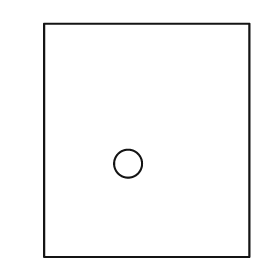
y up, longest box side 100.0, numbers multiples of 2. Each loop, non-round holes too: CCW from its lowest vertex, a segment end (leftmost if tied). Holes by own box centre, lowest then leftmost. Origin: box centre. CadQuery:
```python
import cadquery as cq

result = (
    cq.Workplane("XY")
    .moveTo(-44.0, -50.0)
    .lineTo(44.0, -50.0)
    .lineTo(44.0, 50.0)
    .lineTo(-44.0, 50.0)
    .close()
    .moveTo(-8.0, -10.0)
    .circle(6.0)
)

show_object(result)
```